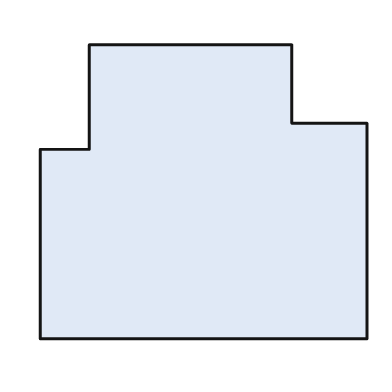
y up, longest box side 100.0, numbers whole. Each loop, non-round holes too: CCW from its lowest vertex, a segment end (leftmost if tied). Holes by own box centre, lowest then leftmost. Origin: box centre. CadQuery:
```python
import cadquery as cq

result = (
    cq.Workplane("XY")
    .moveTo(-50.0, -45.0)
    .lineTo(50.0, -45.0)
    .lineTo(50.0, 21.0)
    .lineTo(27.0, 21.0)
    .lineTo(27.0, 45.0)
    .lineTo(-35.0, 45.0)
    .lineTo(-35.0, 13.0)
    .lineTo(-50.0, 13.0)
    .close()
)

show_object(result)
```